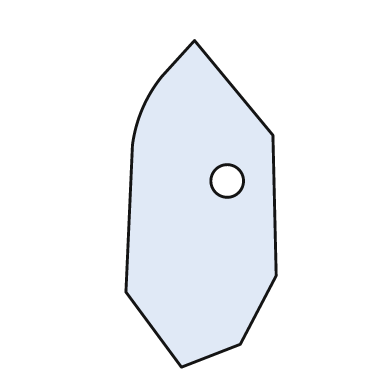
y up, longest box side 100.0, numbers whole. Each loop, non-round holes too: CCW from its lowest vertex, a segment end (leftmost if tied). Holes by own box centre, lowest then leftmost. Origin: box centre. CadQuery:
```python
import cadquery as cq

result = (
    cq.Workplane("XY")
    .moveTo(-6.0, -50.0)
    .lineTo(12.0, -43.0)
    .lineTo(23.0, -22.0)
    .lineTo(22.0, 21.0)
    .lineTo(-2.0, 50.0)
    .lineTo(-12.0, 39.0)
    .threePointArc((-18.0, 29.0), (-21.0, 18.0))
    .lineTo(-23.0, -27.0)
    .close()
    .moveTo(8.0, 7.0)
    .circle(5.0)
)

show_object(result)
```